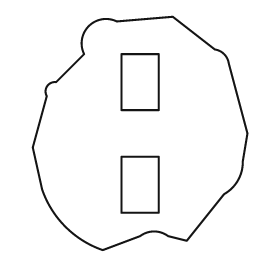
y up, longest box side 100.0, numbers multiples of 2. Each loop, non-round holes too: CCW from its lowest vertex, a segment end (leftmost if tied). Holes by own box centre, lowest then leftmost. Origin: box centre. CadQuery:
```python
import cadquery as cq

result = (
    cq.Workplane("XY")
    .moveTo(-16.0, -50.0)
    .lineTo(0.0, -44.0)
    .threePointArc((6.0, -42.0), (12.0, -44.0))
    .lineTo(20.0, -46.0)
    .lineTo(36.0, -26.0)
    .threePointArc((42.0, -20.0), (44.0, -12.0))
    .lineTo(46.0, 0.0)
    .lineTo(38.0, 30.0)
    .threePointArc((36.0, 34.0), (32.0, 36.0))
    .lineTo(14.0, 50.0)
    .lineTo(-10.0, 48.0)
    .threePointArc((-22.0, 46.0), (-24.0, 34.0))
    .lineTo(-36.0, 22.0)
    .threePointArc((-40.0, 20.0), (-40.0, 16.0))
    .lineTo(-46.0, -6.0)
    .lineTo(-42.0, -24.0)
    .threePointArc((-32.0, -40.0), (-16.0, -50.0))
    .close()
    .moveTo(-8.0, -34.0)
    .lineTo(8.0, -34.0)
    .lineTo(8.0, -10.0)
    .lineTo(-8.0, -10.0)
    .close()
    .moveTo(-8.0, 10.0)
    .lineTo(8.0, 10.0)
    .lineTo(8.0, 34.0)
    .lineTo(-8.0, 34.0)
    .close()
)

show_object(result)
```